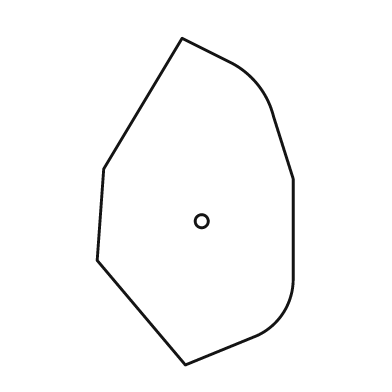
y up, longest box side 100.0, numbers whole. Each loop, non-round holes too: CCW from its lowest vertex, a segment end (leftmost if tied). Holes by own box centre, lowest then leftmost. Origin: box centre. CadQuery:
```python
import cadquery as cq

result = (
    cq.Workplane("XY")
    .moveTo(-3.0, -50.0)
    .lineTo(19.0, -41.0)
    .threePointArc((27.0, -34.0), (30.0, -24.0))
    .lineTo(30.0, 7.0)
    .lineTo(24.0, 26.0)
    .threePointArc((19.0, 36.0), (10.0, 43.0))
    .lineTo(-4.0, 50.0)
    .lineTo(-28.0, 10.0)
    .lineTo(-30.0, -18.0)
    .close()
    .moveTo(2.0, -6.0)
    .circle(2.0)
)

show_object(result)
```